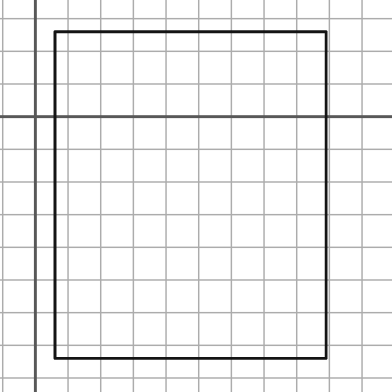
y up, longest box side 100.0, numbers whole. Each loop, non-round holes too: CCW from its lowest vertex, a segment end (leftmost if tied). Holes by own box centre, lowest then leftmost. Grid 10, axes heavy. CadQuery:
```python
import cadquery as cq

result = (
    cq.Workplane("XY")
    .moveTo(6.0, -74.0)
    .lineTo(89.0, -74.0)
    .lineTo(89.0, 26.0)
    .lineTo(6.0, 26.0)
    .close()
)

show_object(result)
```